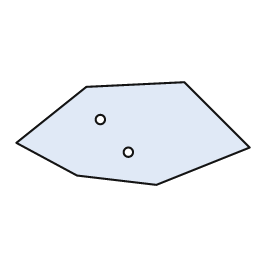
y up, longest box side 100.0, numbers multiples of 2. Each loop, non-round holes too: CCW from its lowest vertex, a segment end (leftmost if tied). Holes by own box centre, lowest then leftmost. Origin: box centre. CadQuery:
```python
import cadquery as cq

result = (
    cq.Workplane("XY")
    .moveTo(10.0, -22.0)
    .lineTo(50.0, -6.0)
    .lineTo(22.0, 22.0)
    .lineTo(-20.0, 20.0)
    .lineTo(-50.0, -4.0)
    .lineTo(-24.0, -18.0)
    .close()
    .moveTo(-2.0, -8.0)
    .circle(2.0)
    .moveTo(-14.0, 6.0)
    .circle(2.0)
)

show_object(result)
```